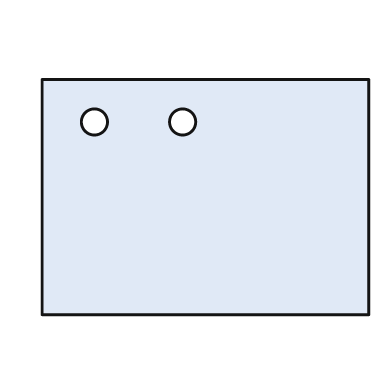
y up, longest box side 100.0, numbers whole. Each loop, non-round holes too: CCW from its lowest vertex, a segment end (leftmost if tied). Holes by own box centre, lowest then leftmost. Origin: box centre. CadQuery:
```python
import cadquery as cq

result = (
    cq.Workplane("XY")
    .moveTo(-50.0, -36.0)
    .lineTo(50.0, -36.0)
    .lineTo(50.0, 36.0)
    .lineTo(-50.0, 36.0)
    .close()
    .moveTo(-34.0, 23.0)
    .circle(4.0)
    .moveTo(-7.0, 23.0)
    .circle(4.0)
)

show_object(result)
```